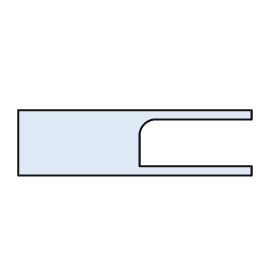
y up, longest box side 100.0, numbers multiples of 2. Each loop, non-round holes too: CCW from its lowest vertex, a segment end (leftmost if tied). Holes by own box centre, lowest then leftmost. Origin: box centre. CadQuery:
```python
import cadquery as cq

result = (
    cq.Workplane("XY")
    .moveTo(-50.0, -14.0)
    .lineTo(50.0, -14.0)
    .lineTo(50.0, -10.0)
    .lineTo(2.0, -10.0)
    .lineTo(2.0, 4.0)
    .threePointArc((4.0, 8.0), (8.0, 10.0))
    .lineTo(50.0, 10.0)
    .lineTo(50.0, 14.0)
    .lineTo(-50.0, 14.0)
    .close()
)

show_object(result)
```